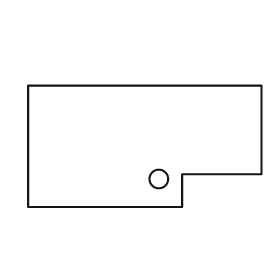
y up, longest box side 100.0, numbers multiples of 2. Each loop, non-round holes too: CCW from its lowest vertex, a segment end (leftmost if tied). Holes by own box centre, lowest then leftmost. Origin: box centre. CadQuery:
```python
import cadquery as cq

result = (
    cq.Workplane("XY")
    .moveTo(-50.0, -26.0)
    .lineTo(16.0, -26.0)
    .lineTo(16.0, -12.0)
    .lineTo(50.0, -12.0)
    .lineTo(50.0, 26.0)
    .lineTo(-50.0, 26.0)
    .close()
    .moveTo(6.0, -14.0)
    .circle(4.0)
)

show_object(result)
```